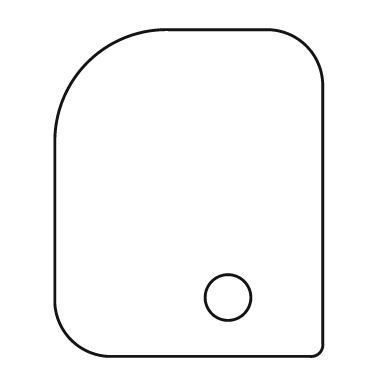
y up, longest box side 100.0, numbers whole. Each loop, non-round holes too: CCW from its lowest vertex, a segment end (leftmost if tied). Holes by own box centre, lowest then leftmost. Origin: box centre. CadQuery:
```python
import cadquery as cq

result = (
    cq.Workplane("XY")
    .moveTo(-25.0, -50.0)
    .lineTo(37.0, -50.0)
    .threePointArc((40.0, -49.0), (41.0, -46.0))
    .lineTo(41.0, 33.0)
    .threePointArc((36.0, 45.0), (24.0, 50.0))
    .lineTo(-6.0, 50.0)
    .threePointArc((-31.0, 40.0), (-41.0, 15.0))
    .lineTo(-41.0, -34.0)
    .threePointArc((-36.0, -45.0), (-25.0, -50.0))
    .close()
    .moveTo(12.0, -32.0)
    .circle(7.0)
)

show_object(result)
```